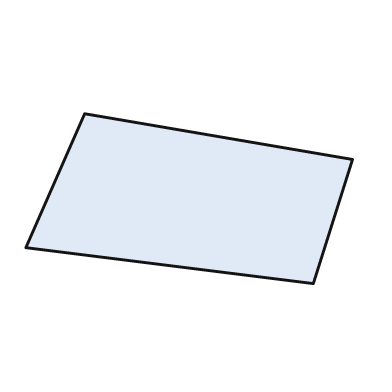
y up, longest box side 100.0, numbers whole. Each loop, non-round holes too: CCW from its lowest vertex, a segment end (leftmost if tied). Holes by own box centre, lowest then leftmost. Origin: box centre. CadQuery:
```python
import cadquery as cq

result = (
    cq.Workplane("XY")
    .moveTo(38.0, -26.0)
    .lineTo(50.0, 12.0)
    .lineTo(-32.0, 26.0)
    .lineTo(-50.0, -15.0)
    .close()
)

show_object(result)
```